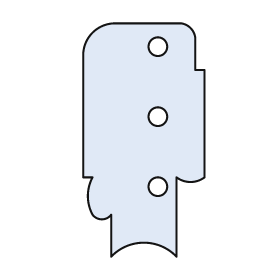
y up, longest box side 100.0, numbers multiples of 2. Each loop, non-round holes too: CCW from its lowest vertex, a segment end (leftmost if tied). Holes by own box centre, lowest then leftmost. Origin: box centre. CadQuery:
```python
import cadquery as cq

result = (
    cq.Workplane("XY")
    .moveTo(-14.0, -50.0)
    .threePointArc((0.0, -44.0), (14.0, -50.0))
    .lineTo(14.0, -16.0)
    .threePointArc((20.0, -18.0), (26.0, -16.0))
    .lineTo(26.0, 30.0)
    .lineTo(22.0, 30.0)
    .lineTo(22.0, 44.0)
    .threePointArc((20.0, 48.0), (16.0, 50.0))
    .lineTo(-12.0, 50.0)
    .threePointArc((-22.0, 46.0), (-26.0, 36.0))
    .lineTo(-26.0, -16.0)
    .lineTo(-22.0, -16.0)
    .threePointArc((-24.0, -24.0), (-22.0, -32.0))
    .threePointArc((-18.0, -34.0), (-14.0, -32.0))
    .close()
    .moveTo(6.0, -20.0)
    .circle(4.0)
    .moveTo(6.0, 10.0)
    .circle(4.0)
    .moveTo(6.0, 40.0)
    .circle(4.0)
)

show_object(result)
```